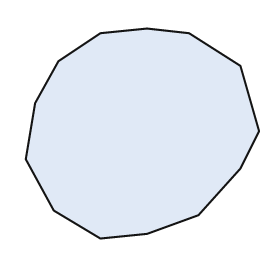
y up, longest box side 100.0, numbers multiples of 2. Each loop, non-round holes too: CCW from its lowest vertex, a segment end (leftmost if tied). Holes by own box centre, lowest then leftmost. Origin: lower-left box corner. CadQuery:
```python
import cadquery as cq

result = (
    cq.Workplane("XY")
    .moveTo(32.0, 0.0)
    .lineTo(52.0, 2.0)
    .lineTo(74.0, 10.0)
    .lineTo(92.0, 30.0)
    .lineTo(100.0, 46.0)
    .lineTo(92.0, 74.0)
    .lineTo(70.0, 88.0)
    .lineTo(52.0, 90.0)
    .lineTo(32.0, 88.0)
    .lineTo(14.0, 76.0)
    .lineTo(4.0, 58.0)
    .lineTo(0.0, 34.0)
    .lineTo(12.0, 12.0)
    .close()
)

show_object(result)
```